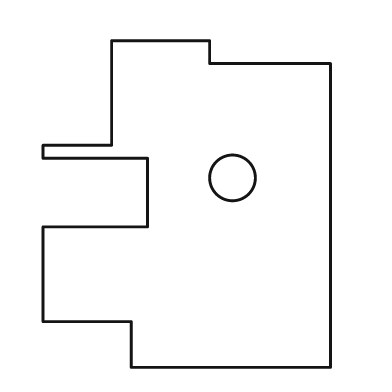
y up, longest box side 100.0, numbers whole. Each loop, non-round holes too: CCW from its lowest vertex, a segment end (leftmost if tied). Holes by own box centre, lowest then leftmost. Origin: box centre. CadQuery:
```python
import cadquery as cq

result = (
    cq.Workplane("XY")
    .moveTo(-17.0, -50.0)
    .lineTo(44.0, -50.0)
    .lineTo(44.0, 43.0)
    .lineTo(7.0, 43.0)
    .lineTo(7.0, 50.0)
    .lineTo(-23.0, 50.0)
    .lineTo(-23.0, 18.0)
    .lineTo(-44.0, 18.0)
    .lineTo(-44.0, 14.0)
    .lineTo(-12.0, 14.0)
    .lineTo(-12.0, -7.0)
    .lineTo(-44.0, -7.0)
    .lineTo(-44.0, -36.0)
    .lineTo(-17.0, -36.0)
    .close()
    .moveTo(14.0, 8.0)
    .circle(7.0)
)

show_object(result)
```